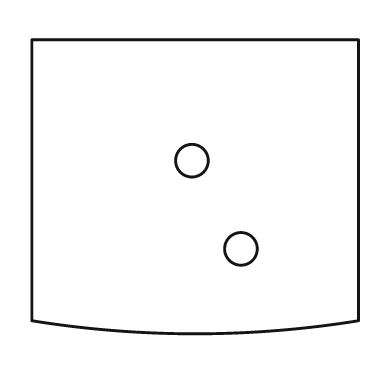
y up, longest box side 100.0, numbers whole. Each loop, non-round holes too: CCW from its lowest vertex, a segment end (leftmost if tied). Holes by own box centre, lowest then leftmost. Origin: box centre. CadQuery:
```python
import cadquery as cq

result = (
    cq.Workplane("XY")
    .moveTo(-50.0, -41.0)
    .threePointArc((0.0, -45.0), (50.0, -41.0))
    .lineTo(50.0, 45.0)
    .lineTo(-50.0, 45.0)
    .close()
    .moveTo(14.0, -19.0)
    .circle(5.0)
    .moveTo(-1.0, 8.0)
    .circle(5.0)
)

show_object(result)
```